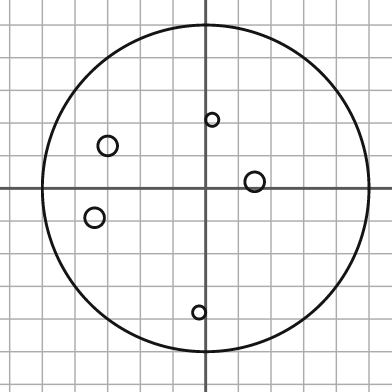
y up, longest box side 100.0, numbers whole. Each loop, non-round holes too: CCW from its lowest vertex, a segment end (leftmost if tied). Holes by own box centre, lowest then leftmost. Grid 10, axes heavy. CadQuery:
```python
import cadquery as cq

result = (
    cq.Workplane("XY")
    .moveTo(0.0, 0.0)
    .circle(50.0)
    .moveTo(-2.0, -38.0)
    .circle(2.0)
    .moveTo(-34.0, -9.0)
    .circle(3.0)
    .moveTo(15.0, 2.0)
    .circle(3.0)
    .moveTo(-30.0, 13.0)
    .circle(3.0)
    .moveTo(2.0, 21.0)
    .circle(2.0)
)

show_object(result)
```